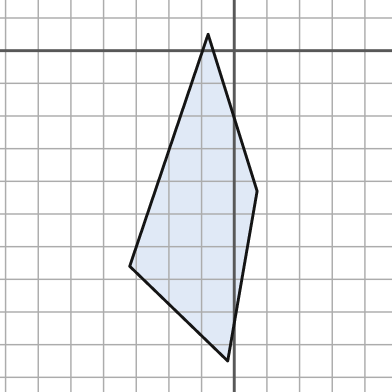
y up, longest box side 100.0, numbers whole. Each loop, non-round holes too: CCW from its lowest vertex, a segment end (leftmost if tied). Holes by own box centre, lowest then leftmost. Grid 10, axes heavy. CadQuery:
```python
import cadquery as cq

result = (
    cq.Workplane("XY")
    .moveTo(-2.0, -95.0)
    .lineTo(7.0, -43.0)
    .lineTo(-8.0, 5.0)
    .lineTo(-32.0, -66.0)
    .close()
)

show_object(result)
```